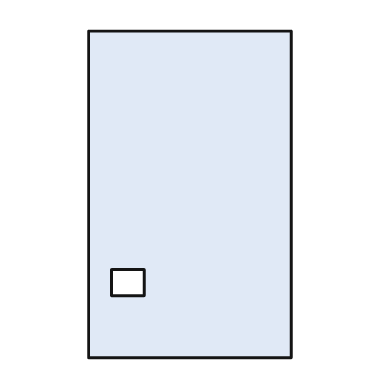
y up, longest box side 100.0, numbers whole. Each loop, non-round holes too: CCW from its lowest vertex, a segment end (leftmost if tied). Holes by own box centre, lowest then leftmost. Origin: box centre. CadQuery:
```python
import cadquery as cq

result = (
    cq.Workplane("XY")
    .moveTo(-31.0, -50.0)
    .lineTo(31.0, -50.0)
    .lineTo(31.0, 50.0)
    .lineTo(-31.0, 50.0)
    .close()
    .moveTo(-24.0, -31.0)
    .lineTo(-14.0, -31.0)
    .lineTo(-14.0, -23.0)
    .lineTo(-24.0, -23.0)
    .close()
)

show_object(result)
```